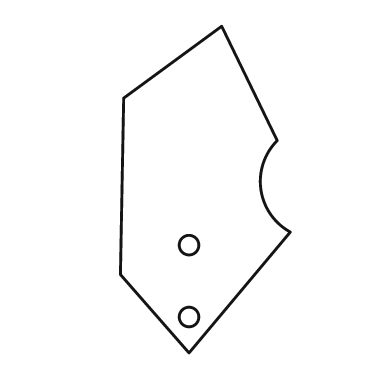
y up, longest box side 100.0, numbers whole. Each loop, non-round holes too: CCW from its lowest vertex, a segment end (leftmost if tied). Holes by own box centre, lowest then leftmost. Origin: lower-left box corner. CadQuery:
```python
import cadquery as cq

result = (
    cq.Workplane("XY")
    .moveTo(21.0, 0.0)
    .lineTo(52.0, 37.0)
    .threePointArc((43.0, 50.0), (48.0, 65.0))
    .lineTo(31.0, 100.0)
    .lineTo(1.0, 78.0)
    .lineTo(0.0, 24.0)
    .close()
    .moveTo(21.0, 11.0)
    .circle(3.0)
    .moveTo(21.0, 33.0)
    .circle(3.0)
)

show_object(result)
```